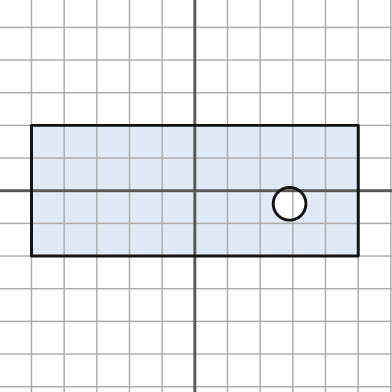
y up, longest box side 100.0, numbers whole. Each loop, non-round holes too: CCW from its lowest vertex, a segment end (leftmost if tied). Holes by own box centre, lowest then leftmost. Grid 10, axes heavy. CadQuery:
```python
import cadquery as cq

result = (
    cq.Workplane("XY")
    .moveTo(-50.0, -20.0)
    .lineTo(50.0, -20.0)
    .lineTo(50.0, 20.0)
    .lineTo(-50.0, 20.0)
    .close()
    .moveTo(29.0, -4.0)
    .circle(5.0)
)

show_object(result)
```